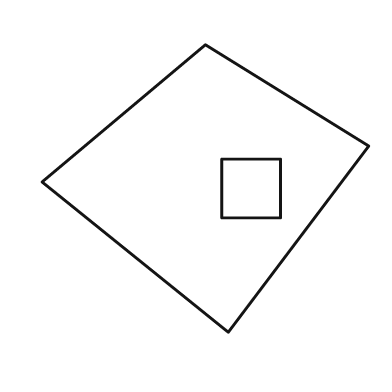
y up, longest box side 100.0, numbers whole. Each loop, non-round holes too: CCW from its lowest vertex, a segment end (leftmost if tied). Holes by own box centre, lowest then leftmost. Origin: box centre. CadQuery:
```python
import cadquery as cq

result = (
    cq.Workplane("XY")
    .moveTo(7.0, -44.0)
    .lineTo(50.0, 13.0)
    .lineTo(0.0, 44.0)
    .lineTo(-50.0, 2.0)
    .close()
    .moveTo(5.0, -9.0)
    .lineTo(23.0, -9.0)
    .lineTo(23.0, 9.0)
    .lineTo(5.0, 9.0)
    .close()
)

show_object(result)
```